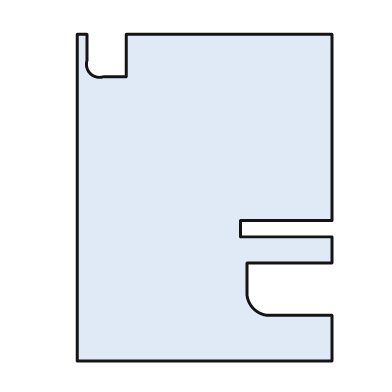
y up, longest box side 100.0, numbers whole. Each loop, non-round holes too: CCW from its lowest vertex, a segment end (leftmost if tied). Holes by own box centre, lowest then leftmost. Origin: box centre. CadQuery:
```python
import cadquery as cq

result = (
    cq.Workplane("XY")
    .moveTo(-39.0, -50.0)
    .lineTo(39.0, -50.0)
    .lineTo(39.0, -36.0)
    .lineTo(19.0, -36.0)
    .threePointArc((15.0, -34.0), (13.0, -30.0))
    .lineTo(13.0, -20.0)
    .lineTo(39.0, -20.0)
    .lineTo(39.0, -12.0)
    .lineTo(11.0, -12.0)
    .lineTo(11.0, -7.0)
    .lineTo(39.0, -7.0)
    .lineTo(39.0, 50.0)
    .lineTo(-24.0, 50.0)
    .lineTo(-24.0, 37.0)
    .lineTo(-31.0, 37.0)
    .threePointArc((-35.0, 38.0), (-36.0, 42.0))
    .lineTo(-36.0, 50.0)
    .lineTo(-39.0, 50.0)
    .close()
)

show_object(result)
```